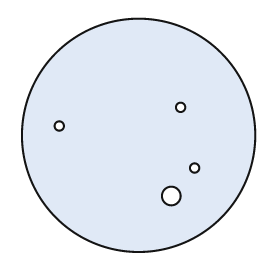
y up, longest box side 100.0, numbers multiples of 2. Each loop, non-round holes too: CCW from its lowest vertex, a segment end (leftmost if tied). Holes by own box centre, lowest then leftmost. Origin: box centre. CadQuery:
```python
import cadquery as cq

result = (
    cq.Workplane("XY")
    .moveTo(0.0, 0.0)
    .circle(50.0)
    .moveTo(14.0, -26.0)
    .circle(4.0)
    .moveTo(24.0, -14.0)
    .circle(2.0)
    .moveTo(-34.0, 4.0)
    .circle(2.0)
    .moveTo(18.0, 12.0)
    .circle(2.0)
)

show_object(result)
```